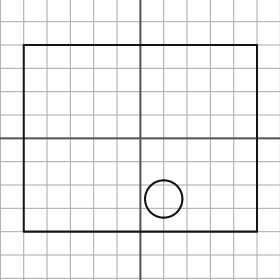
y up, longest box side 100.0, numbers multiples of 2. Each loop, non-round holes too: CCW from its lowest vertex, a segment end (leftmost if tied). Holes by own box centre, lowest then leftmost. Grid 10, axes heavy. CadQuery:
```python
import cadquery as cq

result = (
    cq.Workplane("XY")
    .moveTo(-50.0, -40.0)
    .lineTo(50.0, -40.0)
    .lineTo(50.0, 40.0)
    .lineTo(-50.0, 40.0)
    .close()
    .moveTo(10.0, -26.0)
    .circle(8.0)
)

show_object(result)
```